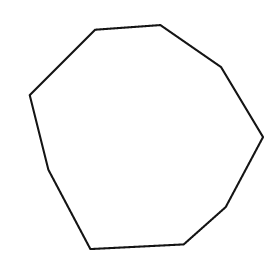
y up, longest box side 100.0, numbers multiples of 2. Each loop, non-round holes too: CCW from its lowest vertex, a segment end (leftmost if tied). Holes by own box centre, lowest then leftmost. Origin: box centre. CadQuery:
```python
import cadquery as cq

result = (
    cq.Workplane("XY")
    .moveTo(-24.0, -48.0)
    .lineTo(16.0, -46.0)
    .lineTo(34.0, -30.0)
    .lineTo(50.0, 0.0)
    .lineTo(32.0, 30.0)
    .lineTo(6.0, 48.0)
    .lineTo(-22.0, 46.0)
    .lineTo(-50.0, 18.0)
    .lineTo(-42.0, -14.0)
    .close()
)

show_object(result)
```